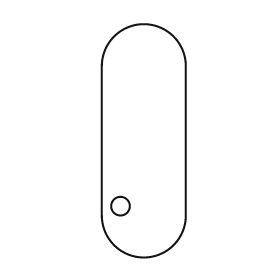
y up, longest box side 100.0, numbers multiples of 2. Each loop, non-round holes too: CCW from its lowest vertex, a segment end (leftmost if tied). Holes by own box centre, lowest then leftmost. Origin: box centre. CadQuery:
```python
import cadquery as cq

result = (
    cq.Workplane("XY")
    .moveTo(-18.0, -32.0)
    .threePointArc((0.0, -50.0), (18.0, -32.0))
    .lineTo(18.0, 32.0)
    .threePointArc((0.0, 50.0), (-18.0, 32.0))
    .close()
    .moveTo(-10.0, -28.0)
    .circle(4.0)
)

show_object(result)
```